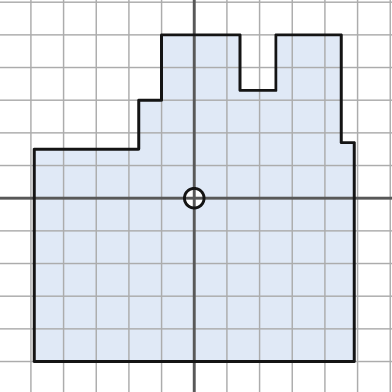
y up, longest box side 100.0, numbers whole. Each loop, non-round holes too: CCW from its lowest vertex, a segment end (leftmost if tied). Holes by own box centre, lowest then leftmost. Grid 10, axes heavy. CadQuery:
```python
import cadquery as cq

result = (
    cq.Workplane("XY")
    .moveTo(-49.0, -50.0)
    .lineTo(49.0, -50.0)
    .lineTo(49.0, 17.0)
    .lineTo(45.0, 17.0)
    .lineTo(45.0, 50.0)
    .lineTo(25.0, 50.0)
    .lineTo(25.0, 33.0)
    .lineTo(14.0, 33.0)
    .lineTo(14.0, 50.0)
    .lineTo(-10.0, 50.0)
    .lineTo(-10.0, 30.0)
    .lineTo(-17.0, 30.0)
    .lineTo(-17.0, 15.0)
    .lineTo(-49.0, 15.0)
    .close()
    .moveTo(0.0, 0.0)
    .circle(3.0)
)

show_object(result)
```